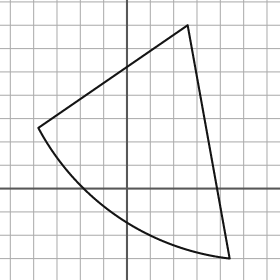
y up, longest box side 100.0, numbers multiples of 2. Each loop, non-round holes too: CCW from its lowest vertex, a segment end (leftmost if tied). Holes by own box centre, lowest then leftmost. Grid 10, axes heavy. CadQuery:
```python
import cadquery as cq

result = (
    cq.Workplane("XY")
    .moveTo(44.0, -30.0)
    .lineTo(26.0, 70.0)
    .lineTo(-38.0, 26.0)
    .threePointArc((-4.0, -12.0), (44.0, -30.0))
    .close()
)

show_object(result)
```